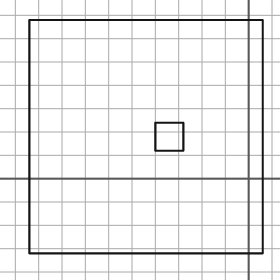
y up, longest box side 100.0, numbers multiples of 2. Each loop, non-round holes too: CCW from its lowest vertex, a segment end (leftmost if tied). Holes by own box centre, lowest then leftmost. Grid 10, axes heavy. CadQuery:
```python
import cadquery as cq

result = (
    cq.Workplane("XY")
    .moveTo(-94.0, -32.0)
    .lineTo(6.0, -32.0)
    .lineTo(6.0, 68.0)
    .lineTo(-94.0, 68.0)
    .close()
    .moveTo(-40.0, 12.0)
    .lineTo(-28.0, 12.0)
    .lineTo(-28.0, 24.0)
    .lineTo(-40.0, 24.0)
    .close()
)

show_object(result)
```